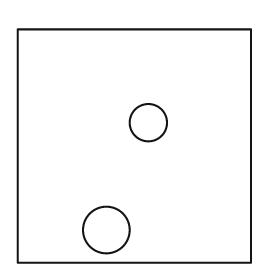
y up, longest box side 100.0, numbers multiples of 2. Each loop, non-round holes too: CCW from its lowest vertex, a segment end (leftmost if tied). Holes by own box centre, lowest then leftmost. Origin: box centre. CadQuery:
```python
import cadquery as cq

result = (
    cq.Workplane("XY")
    .moveTo(-50.0, -50.0)
    .lineTo(50.0, -50.0)
    .lineTo(50.0, 50.0)
    .lineTo(-50.0, 50.0)
    .close()
    .moveTo(-12.0, -36.0)
    .circle(10.0)
    .moveTo(6.0, 10.0)
    .circle(8.0)
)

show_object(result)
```